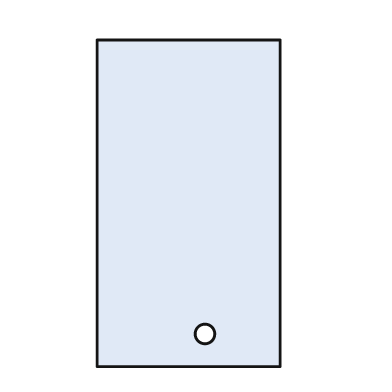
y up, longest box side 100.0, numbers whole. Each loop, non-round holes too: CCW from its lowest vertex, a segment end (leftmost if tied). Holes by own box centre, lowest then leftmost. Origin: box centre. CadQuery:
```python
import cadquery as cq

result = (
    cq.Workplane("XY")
    .moveTo(-28.0, -50.0)
    .lineTo(28.0, -50.0)
    .lineTo(28.0, 50.0)
    .lineTo(-28.0, 50.0)
    .close()
    .moveTo(5.0, -40.0)
    .circle(3.0)
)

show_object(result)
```